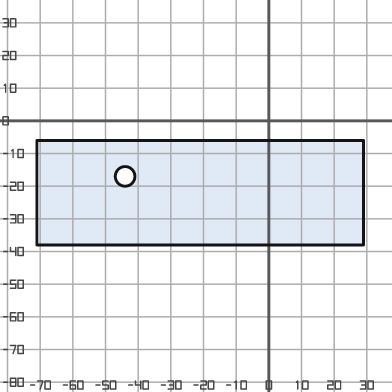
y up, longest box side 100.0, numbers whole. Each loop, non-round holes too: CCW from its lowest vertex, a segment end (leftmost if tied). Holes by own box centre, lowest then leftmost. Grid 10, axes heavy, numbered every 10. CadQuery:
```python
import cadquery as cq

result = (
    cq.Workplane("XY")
    .moveTo(-71.0, -38.0)
    .lineTo(29.0, -38.0)
    .lineTo(29.0, -6.0)
    .lineTo(-71.0, -6.0)
    .close()
    .moveTo(-44.0, -17.0)
    .circle(3.0)
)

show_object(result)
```